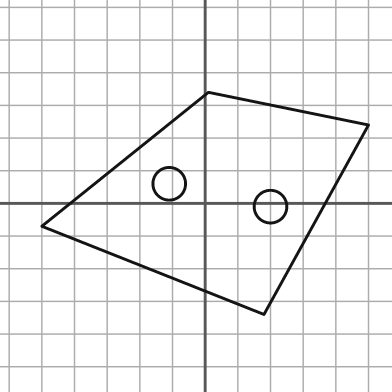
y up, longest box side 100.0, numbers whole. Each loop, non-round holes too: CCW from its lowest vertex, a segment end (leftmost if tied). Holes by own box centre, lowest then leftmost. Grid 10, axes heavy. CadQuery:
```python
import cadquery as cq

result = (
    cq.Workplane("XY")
    .moveTo(18.0, -34.0)
    .lineTo(50.0, 24.0)
    .lineTo(1.0, 34.0)
    .lineTo(-50.0, -7.0)
    .close()
    .moveTo(20.0, -1.0)
    .circle(5.0)
    .moveTo(-11.0, 6.0)
    .circle(5.0)
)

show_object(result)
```